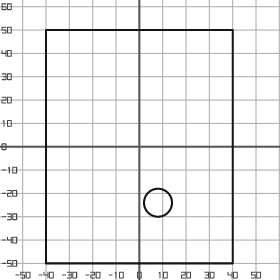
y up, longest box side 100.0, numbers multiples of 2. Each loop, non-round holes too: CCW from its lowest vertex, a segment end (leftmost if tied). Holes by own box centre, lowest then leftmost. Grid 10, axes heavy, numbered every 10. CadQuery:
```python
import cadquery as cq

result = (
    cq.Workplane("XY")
    .moveTo(-40.0, -50.0)
    .lineTo(40.0, -50.0)
    .lineTo(40.0, 50.0)
    .lineTo(-40.0, 50.0)
    .close()
    .moveTo(8.0, -24.0)
    .circle(6.0)
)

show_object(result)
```